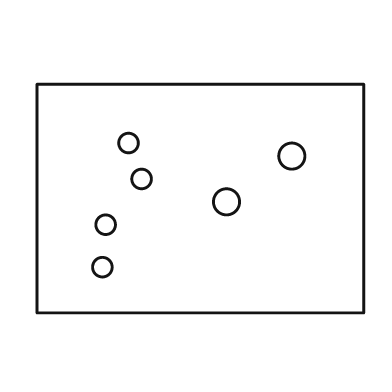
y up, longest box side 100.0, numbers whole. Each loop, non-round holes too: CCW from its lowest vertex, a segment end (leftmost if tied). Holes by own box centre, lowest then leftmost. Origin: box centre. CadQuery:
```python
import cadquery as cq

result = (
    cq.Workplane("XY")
    .moveTo(-50.0, -35.0)
    .lineTo(50.0, -35.0)
    .lineTo(50.0, 35.0)
    .lineTo(-50.0, 35.0)
    .close()
    .moveTo(-30.0, -21.0)
    .circle(3.0)
    .moveTo(-29.0, -8.0)
    .circle(3.0)
    .moveTo(8.0, -1.0)
    .circle(4.0)
    .moveTo(-18.0, 6.0)
    .circle(3.0)
    .moveTo(28.0, 13.0)
    .circle(4.0)
    .moveTo(-22.0, 17.0)
    .circle(3.0)
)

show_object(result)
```